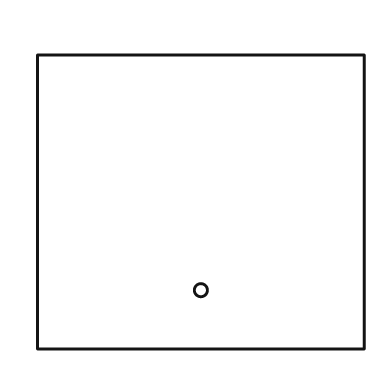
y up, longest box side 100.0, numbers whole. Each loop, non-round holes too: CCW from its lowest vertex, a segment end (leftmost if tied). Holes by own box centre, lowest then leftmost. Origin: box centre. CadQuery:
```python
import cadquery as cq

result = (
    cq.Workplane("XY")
    .moveTo(-50.0, -45.0)
    .lineTo(50.0, -45.0)
    .lineTo(50.0, 45.0)
    .lineTo(-50.0, 45.0)
    .close()
    .moveTo(0.0, -27.0)
    .circle(2.0)
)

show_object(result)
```